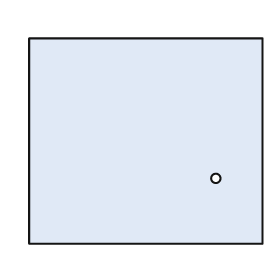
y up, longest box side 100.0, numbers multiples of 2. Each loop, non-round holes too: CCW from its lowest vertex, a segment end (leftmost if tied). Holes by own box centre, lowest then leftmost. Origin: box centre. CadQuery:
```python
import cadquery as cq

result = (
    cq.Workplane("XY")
    .moveTo(-50.0, -44.0)
    .lineTo(50.0, -44.0)
    .lineTo(50.0, 44.0)
    .lineTo(-50.0, 44.0)
    .close()
    .moveTo(30.0, -16.0)
    .circle(2.0)
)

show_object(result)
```